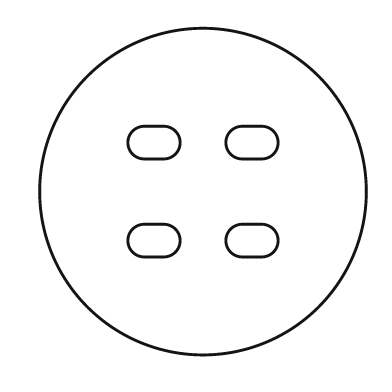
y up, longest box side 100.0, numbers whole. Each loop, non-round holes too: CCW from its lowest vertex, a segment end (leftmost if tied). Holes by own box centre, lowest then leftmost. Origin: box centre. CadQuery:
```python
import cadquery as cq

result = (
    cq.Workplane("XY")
    .moveTo(0.0, 0.0)
    .circle(50.0)
    .moveTo(-18.0, -20.0)
    .lineTo(-12.0, -20.0)
    .threePointArc((-7.0, -15.0), (-12.0, -10.0))
    .lineTo(-18.0, -10.0)
    .threePointArc((-23.0, -15.0), (-18.0, -20.0))
    .close()
    .moveTo(12.0, -20.0)
    .lineTo(18.0, -20.0)
    .threePointArc((23.0, -15.0), (18.0, -10.0))
    .lineTo(12.0, -10.0)
    .threePointArc((7.0, -15.0), (12.0, -20.0))
    .close()
    .moveTo(-18.0, 10.0)
    .lineTo(-12.0, 10.0)
    .threePointArc((-7.0, 15.0), (-12.0, 20.0))
    .lineTo(-18.0, 20.0)
    .threePointArc((-23.0, 15.0), (-18.0, 10.0))
    .close()
    .moveTo(12.0, 10.0)
    .lineTo(18.0, 10.0)
    .threePointArc((23.0, 15.0), (18.0, 20.0))
    .lineTo(12.0, 20.0)
    .threePointArc((7.0, 15.0), (12.0, 10.0))
    .close()
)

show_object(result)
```